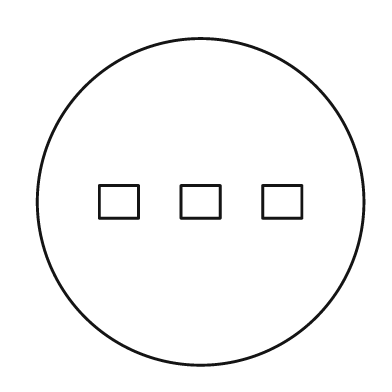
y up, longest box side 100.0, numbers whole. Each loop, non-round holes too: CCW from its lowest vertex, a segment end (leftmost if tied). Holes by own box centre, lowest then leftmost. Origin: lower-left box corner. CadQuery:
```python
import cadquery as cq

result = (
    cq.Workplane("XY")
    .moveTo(50.0, 50.0)
    .circle(50.0)
    .moveTo(19.0, 45.0)
    .lineTo(31.0, 45.0)
    .lineTo(31.0, 55.0)
    .lineTo(19.0, 55.0)
    .close()
    .moveTo(44.0, 45.0)
    .lineTo(56.0, 45.0)
    .lineTo(56.0, 55.0)
    .lineTo(44.0, 55.0)
    .close()
    .moveTo(69.0, 45.0)
    .lineTo(81.0, 45.0)
    .lineTo(81.0, 55.0)
    .lineTo(69.0, 55.0)
    .close()
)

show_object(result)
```